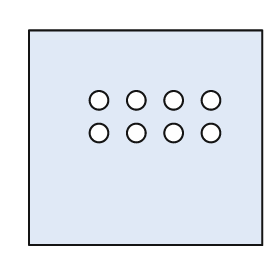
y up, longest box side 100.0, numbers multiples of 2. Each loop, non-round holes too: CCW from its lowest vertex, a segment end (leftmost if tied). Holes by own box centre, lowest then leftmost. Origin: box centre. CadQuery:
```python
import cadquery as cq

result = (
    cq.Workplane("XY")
    .moveTo(-50.0, -46.0)
    .lineTo(50.0, -46.0)
    .lineTo(50.0, 46.0)
    .lineTo(-50.0, 46.0)
    .close()
    .moveTo(-20.0, 2.0)
    .circle(4.0)
    .moveTo(-4.0, 2.0)
    .circle(4.0)
    .moveTo(12.0, 2.0)
    .circle(4.0)
    .moveTo(28.0, 2.0)
    .circle(4.0)
    .moveTo(-20.0, 16.0)
    .circle(4.0)
    .moveTo(-4.0, 16.0)
    .circle(4.0)
    .moveTo(12.0, 16.0)
    .circle(4.0)
    .moveTo(28.0, 16.0)
    .circle(4.0)
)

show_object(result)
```